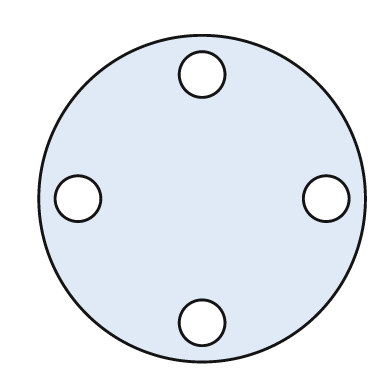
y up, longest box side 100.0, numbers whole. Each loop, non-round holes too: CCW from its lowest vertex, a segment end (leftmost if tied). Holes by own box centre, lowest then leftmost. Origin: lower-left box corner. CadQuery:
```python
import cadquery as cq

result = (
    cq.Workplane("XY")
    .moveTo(50.0, 50.0)
    .circle(50.0)
    .moveTo(50.0, 12.0)
    .circle(7.0)
    .moveTo(12.0, 50.0)
    .circle(7.0)
    .moveTo(88.0, 50.0)
    .circle(7.0)
    .moveTo(50.0, 88.0)
    .circle(7.0)
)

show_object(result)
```